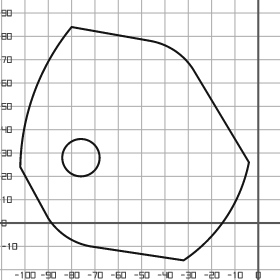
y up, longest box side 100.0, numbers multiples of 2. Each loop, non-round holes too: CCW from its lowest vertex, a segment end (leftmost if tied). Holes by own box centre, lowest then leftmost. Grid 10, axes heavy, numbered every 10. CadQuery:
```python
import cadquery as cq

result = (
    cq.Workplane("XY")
    .moveTo(-32.0, -16.0)
    .threePointArc((-14.0, 2.0), (-4.0, 26.0))
    .lineTo(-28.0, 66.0)
    .threePointArc((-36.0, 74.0), (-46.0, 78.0))
    .lineTo(-80.0, 84.0)
    .threePointArc((-96.0, 56.0), (-102.0, 24.0))
    .lineTo(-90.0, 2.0)
    .threePointArc((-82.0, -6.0), (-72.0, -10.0))
    .close()
    .moveTo(-76.0, 28.0)
    .circle(8.0)
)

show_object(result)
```